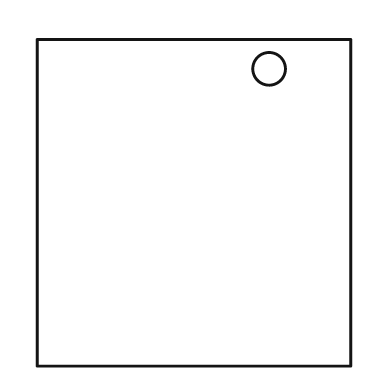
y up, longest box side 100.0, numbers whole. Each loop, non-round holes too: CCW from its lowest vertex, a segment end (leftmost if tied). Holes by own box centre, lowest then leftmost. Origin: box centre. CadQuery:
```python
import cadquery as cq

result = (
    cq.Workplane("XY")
    .moveTo(-48.0, -50.0)
    .lineTo(48.0, -50.0)
    .lineTo(48.0, 50.0)
    .lineTo(-48.0, 50.0)
    .close()
    .moveTo(23.0, 41.0)
    .circle(5.0)
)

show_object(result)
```